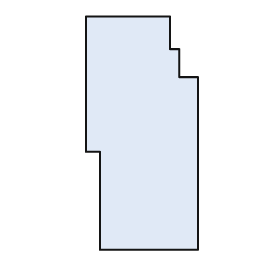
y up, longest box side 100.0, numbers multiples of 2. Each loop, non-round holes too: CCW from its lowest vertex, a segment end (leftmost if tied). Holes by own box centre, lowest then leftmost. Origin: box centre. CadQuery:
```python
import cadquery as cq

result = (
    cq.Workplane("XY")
    .moveTo(-18.0, -50.0)
    .lineTo(24.0, -50.0)
    .lineTo(24.0, 24.0)
    .lineTo(16.0, 24.0)
    .lineTo(16.0, 36.0)
    .lineTo(12.0, 36.0)
    .lineTo(12.0, 50.0)
    .lineTo(-24.0, 50.0)
    .lineTo(-24.0, -8.0)
    .lineTo(-18.0, -8.0)
    .close()
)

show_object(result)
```